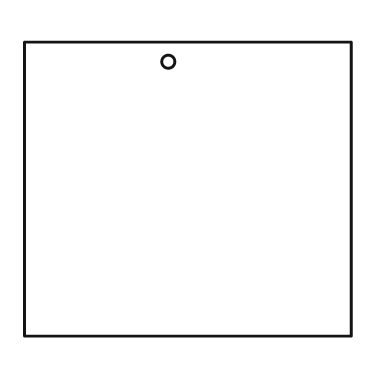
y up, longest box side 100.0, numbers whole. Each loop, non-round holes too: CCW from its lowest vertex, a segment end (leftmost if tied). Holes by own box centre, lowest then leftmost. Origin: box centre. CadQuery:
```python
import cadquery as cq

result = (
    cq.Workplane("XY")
    .moveTo(-50.0, -45.0)
    .lineTo(50.0, -45.0)
    .lineTo(50.0, 45.0)
    .lineTo(-50.0, 45.0)
    .close()
    .moveTo(-6.0, 39.0)
    .circle(2.0)
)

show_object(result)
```